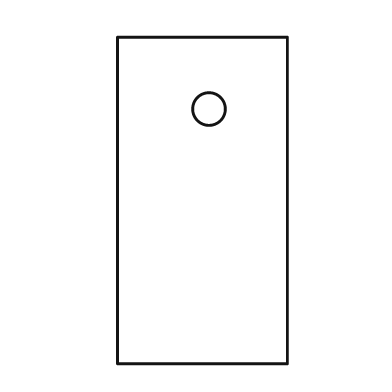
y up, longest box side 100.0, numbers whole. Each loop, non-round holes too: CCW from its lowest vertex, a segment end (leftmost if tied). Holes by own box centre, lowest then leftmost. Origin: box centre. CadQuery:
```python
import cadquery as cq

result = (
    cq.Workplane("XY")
    .moveTo(-26.0, -50.0)
    .lineTo(26.0, -50.0)
    .lineTo(26.0, 50.0)
    .lineTo(-26.0, 50.0)
    .close()
    .moveTo(2.0, 28.0)
    .circle(5.0)
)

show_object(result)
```